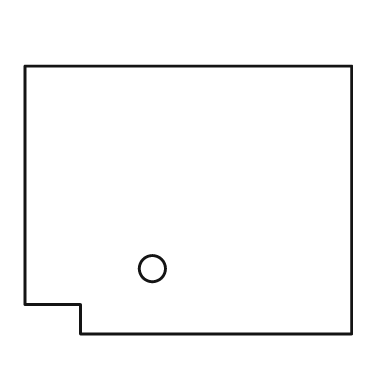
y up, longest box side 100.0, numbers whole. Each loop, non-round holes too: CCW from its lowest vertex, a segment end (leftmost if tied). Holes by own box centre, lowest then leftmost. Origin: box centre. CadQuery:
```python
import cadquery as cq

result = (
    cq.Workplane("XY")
    .moveTo(-33.0, -41.0)
    .lineTo(50.0, -41.0)
    .lineTo(50.0, 41.0)
    .lineTo(-50.0, 41.0)
    .lineTo(-50.0, -32.0)
    .lineTo(-33.0, -32.0)
    .close()
    .moveTo(-11.0, -21.0)
    .circle(4.0)
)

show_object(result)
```